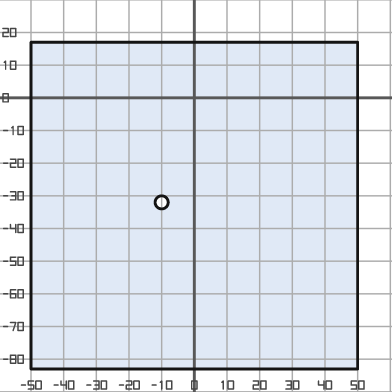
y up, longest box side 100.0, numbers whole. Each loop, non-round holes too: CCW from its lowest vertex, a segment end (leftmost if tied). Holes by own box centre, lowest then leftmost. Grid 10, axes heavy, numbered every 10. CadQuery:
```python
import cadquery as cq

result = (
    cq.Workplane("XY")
    .moveTo(-50.0, -83.0)
    .lineTo(50.0, -83.0)
    .lineTo(50.0, 17.0)
    .lineTo(-50.0, 17.0)
    .close()
    .moveTo(-10.0, -32.0)
    .circle(2.0)
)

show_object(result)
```